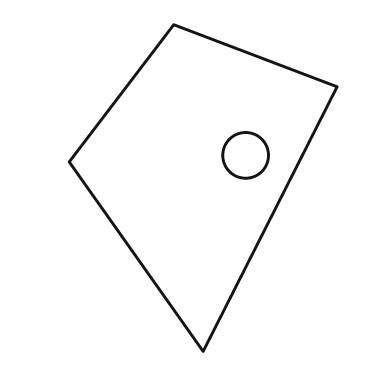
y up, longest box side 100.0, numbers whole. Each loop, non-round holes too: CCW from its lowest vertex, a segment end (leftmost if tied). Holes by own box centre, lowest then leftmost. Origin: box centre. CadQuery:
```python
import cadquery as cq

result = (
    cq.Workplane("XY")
    .moveTo(0.0, -50.0)
    .lineTo(41.0, 31.0)
    .lineTo(-9.0, 50.0)
    .lineTo(-41.0, 8.0)
    .close()
    .moveTo(13.0, 10.0)
    .circle(7.0)
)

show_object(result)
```